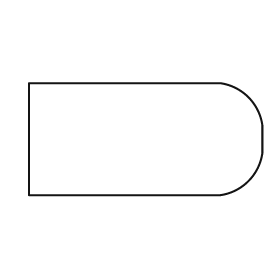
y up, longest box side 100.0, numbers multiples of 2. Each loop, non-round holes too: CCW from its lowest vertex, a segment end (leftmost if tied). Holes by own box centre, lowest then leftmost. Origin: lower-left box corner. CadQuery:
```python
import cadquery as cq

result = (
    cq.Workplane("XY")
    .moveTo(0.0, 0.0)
    .lineTo(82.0, 0.0)
    .threePointArc((94.0, 6.0), (100.0, 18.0))
    .lineTo(100.0, 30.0)
    .threePointArc((94.0, 42.0), (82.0, 48.0))
    .lineTo(0.0, 48.0)
    .close()
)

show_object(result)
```